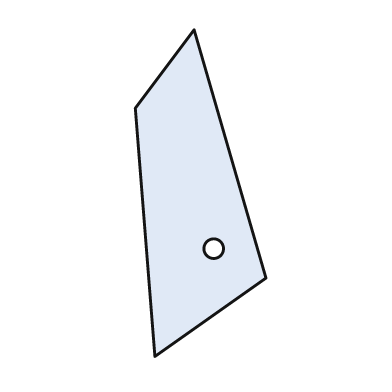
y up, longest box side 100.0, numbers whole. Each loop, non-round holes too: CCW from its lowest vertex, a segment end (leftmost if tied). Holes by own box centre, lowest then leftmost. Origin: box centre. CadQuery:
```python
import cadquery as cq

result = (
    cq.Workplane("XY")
    .moveTo(-14.0, -50.0)
    .lineTo(20.0, -26.0)
    .lineTo(-2.0, 50.0)
    .lineTo(-20.0, 26.0)
    .close()
    .moveTo(4.0, -17.0)
    .circle(3.0)
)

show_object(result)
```